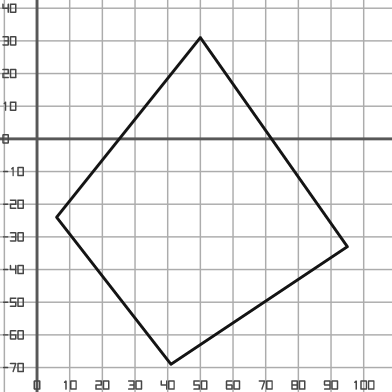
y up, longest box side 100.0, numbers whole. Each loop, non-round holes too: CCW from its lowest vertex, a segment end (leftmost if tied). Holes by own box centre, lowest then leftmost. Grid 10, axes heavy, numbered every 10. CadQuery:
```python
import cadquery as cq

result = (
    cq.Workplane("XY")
    .moveTo(41.0, -69.0)
    .lineTo(95.0, -33.0)
    .lineTo(50.0, 31.0)
    .lineTo(6.0, -24.0)
    .close()
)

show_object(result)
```